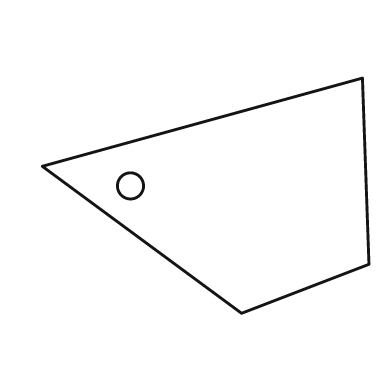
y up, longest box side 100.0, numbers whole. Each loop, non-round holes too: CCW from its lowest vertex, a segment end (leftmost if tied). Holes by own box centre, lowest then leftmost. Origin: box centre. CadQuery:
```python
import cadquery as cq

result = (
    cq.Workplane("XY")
    .moveTo(11.0, -36.0)
    .lineTo(50.0, -21.0)
    .lineTo(48.0, 36.0)
    .lineTo(-50.0, 9.0)
    .close()
    .moveTo(-23.0, 3.0)
    .circle(4.0)
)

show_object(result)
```